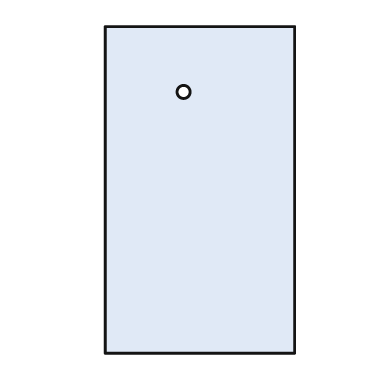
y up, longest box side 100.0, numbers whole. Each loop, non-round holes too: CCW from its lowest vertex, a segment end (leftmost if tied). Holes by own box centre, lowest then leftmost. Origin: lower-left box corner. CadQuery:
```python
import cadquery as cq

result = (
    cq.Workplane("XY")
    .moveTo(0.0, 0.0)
    .lineTo(58.0, 0.0)
    .lineTo(58.0, 100.0)
    .lineTo(0.0, 100.0)
    .close()
    .moveTo(24.0, 80.0)
    .circle(2.0)
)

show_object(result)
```